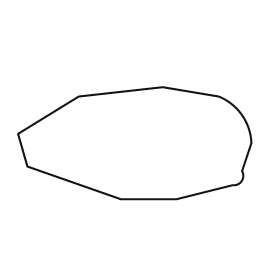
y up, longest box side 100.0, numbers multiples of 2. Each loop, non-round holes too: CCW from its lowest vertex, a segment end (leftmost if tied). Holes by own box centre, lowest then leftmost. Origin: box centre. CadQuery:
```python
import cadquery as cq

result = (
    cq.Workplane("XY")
    .moveTo(-6.0, -24.0)
    .lineTo(18.0, -24.0)
    .lineTo(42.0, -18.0)
    .threePointArc((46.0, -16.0), (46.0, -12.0))
    .lineTo(50.0, 0.0)
    .threePointArc((46.0, 12.0), (36.0, 20.0))
    .lineTo(12.0, 24.0)
    .lineTo(-24.0, 20.0)
    .lineTo(-50.0, 4.0)
    .lineTo(-46.0, -10.0)
    .close()
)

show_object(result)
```